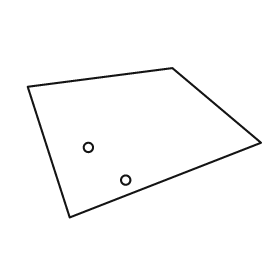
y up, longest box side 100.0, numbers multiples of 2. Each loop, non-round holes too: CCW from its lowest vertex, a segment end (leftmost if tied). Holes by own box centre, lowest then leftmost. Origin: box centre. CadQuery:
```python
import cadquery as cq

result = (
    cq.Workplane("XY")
    .moveTo(-32.0, -32.0)
    .lineTo(50.0, 0.0)
    .lineTo(12.0, 32.0)
    .lineTo(-50.0, 24.0)
    .close()
    .moveTo(-8.0, -16.0)
    .circle(2.0)
    .moveTo(-24.0, -2.0)
    .circle(2.0)
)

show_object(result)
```